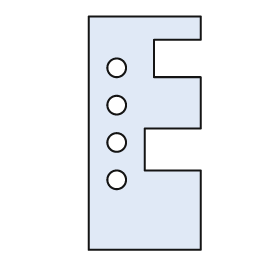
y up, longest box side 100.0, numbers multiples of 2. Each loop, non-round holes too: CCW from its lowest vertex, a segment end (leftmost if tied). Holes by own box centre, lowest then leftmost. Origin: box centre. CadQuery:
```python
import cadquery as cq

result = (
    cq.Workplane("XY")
    .moveTo(-24.0, -50.0)
    .lineTo(24.0, -50.0)
    .lineTo(24.0, -16.0)
    .lineTo(0.0, -16.0)
    .lineTo(0.0, 2.0)
    .lineTo(24.0, 2.0)
    .lineTo(24.0, 24.0)
    .lineTo(4.0, 24.0)
    .lineTo(4.0, 40.0)
    .lineTo(24.0, 40.0)
    .lineTo(24.0, 50.0)
    .lineTo(-24.0, 50.0)
    .close()
    .moveTo(-12.0, -20.0)
    .circle(4.0)
    .moveTo(-12.0, -4.0)
    .circle(4.0)
    .moveTo(-12.0, 12.0)
    .circle(4.0)
    .moveTo(-12.0, 28.0)
    .circle(4.0)
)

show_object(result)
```